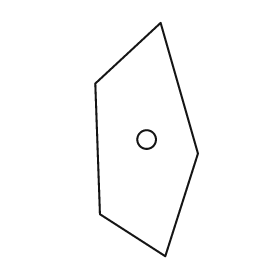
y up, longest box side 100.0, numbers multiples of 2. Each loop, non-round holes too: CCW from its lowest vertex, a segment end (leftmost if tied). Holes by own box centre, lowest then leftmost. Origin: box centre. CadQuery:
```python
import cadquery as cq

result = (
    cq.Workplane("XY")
    .moveTo(8.0, -50.0)
    .lineTo(22.0, -6.0)
    .lineTo(6.0, 50.0)
    .lineTo(-22.0, 24.0)
    .lineTo(-20.0, -32.0)
    .close()
    .moveTo(0.0, 0.0)
    .circle(4.0)
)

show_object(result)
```